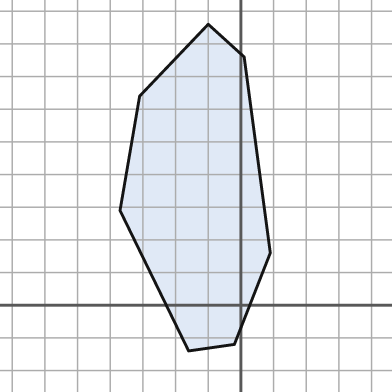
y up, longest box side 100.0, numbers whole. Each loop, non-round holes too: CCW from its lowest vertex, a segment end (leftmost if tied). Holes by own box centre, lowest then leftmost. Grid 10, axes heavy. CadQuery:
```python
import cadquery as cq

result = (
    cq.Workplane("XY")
    .moveTo(-16.0, -14.0)
    .lineTo(-2.0, -12.0)
    .lineTo(9.0, 16.0)
    .lineTo(1.0, 76.0)
    .lineTo(-10.0, 86.0)
    .lineTo(-31.0, 64.0)
    .lineTo(-37.0, 29.0)
    .close()
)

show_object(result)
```